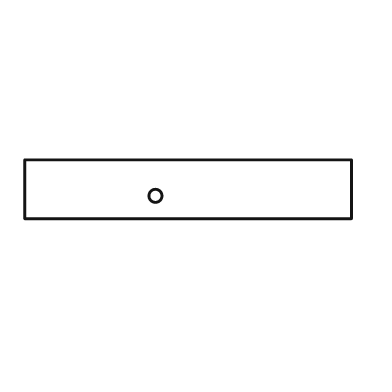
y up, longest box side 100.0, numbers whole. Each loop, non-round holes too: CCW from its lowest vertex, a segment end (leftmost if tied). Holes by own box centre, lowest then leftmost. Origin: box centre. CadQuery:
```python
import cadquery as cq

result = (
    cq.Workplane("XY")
    .moveTo(-50.0, -9.0)
    .lineTo(50.0, -9.0)
    .lineTo(50.0, 9.0)
    .lineTo(-50.0, 9.0)
    .close()
    .moveTo(-10.0, -2.0)
    .circle(2.0)
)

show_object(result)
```